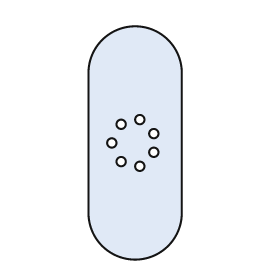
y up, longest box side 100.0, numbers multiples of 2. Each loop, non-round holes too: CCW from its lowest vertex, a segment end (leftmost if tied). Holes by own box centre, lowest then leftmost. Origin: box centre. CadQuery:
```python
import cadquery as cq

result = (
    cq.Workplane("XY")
    .moveTo(-20.0, -30.0)
    .threePointArc((0.0, -50.0), (20.0, -30.0))
    .lineTo(20.0, 30.0)
    .threePointArc((0.0, 50.0), (-20.0, 30.0))
    .close()
    .moveTo(2.0, -10.0)
    .circle(2.0)
    .moveTo(-6.0, -8.0)
    .circle(2.0)
    .moveTo(8.0, -4.0)
    .circle(2.0)
    .moveTo(-10.0, 0.0)
    .circle(2.0)
    .moveTo(8.0, 4.0)
    .circle(2.0)
    .moveTo(-6.0, 8.0)
    .circle(2.0)
    .moveTo(2.0, 10.0)
    .circle(2.0)
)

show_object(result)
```